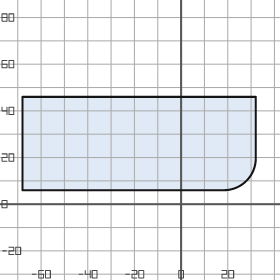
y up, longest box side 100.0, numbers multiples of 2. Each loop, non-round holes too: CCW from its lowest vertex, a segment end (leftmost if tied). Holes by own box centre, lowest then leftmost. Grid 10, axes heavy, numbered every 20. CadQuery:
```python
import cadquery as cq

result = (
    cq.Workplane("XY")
    .moveTo(-68.0, 6.0)
    .lineTo(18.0, 6.0)
    .threePointArc((28.0, 10.0), (32.0, 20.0))
    .lineTo(32.0, 46.0)
    .lineTo(-68.0, 46.0)
    .close()
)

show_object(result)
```